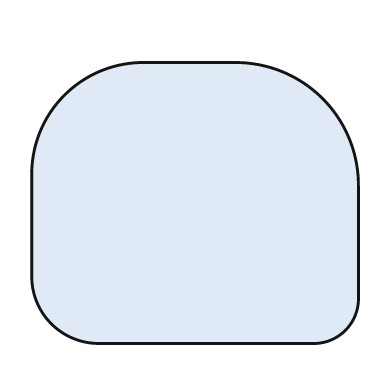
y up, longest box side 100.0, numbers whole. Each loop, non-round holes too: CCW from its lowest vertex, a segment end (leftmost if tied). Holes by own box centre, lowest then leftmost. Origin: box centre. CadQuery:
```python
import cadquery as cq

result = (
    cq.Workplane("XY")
    .moveTo(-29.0, -43.0)
    .lineTo(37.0, -43.0)
    .threePointArc((46.0, -39.0), (50.0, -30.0))
    .lineTo(50.0, 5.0)
    .threePointArc((39.0, 32.0), (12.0, 43.0))
    .lineTo(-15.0, 43.0)
    .threePointArc((-40.0, 33.0), (-50.0, 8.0))
    .lineTo(-50.0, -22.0)
    .threePointArc((-44.0, -37.0), (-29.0, -43.0))
    .close()
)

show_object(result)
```